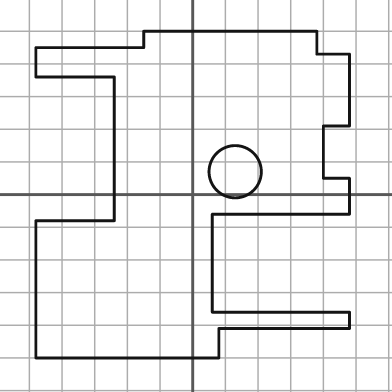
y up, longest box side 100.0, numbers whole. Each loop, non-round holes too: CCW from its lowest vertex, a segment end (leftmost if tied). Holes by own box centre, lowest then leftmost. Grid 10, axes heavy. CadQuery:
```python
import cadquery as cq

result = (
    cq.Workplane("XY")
    .moveTo(-48.0, -50.0)
    .lineTo(8.0, -50.0)
    .lineTo(8.0, -41.0)
    .lineTo(48.0, -41.0)
    .lineTo(48.0, -36.0)
    .lineTo(6.0, -36.0)
    .lineTo(6.0, -6.0)
    .lineTo(48.0, -6.0)
    .lineTo(48.0, 5.0)
    .lineTo(40.0, 5.0)
    .lineTo(40.0, 21.0)
    .lineTo(48.0, 21.0)
    .lineTo(48.0, 43.0)
    .lineTo(38.0, 43.0)
    .lineTo(38.0, 50.0)
    .lineTo(-15.0, 50.0)
    .lineTo(-15.0, 45.0)
    .lineTo(-48.0, 45.0)
    .lineTo(-48.0, 36.0)
    .lineTo(-24.0, 36.0)
    .lineTo(-24.0, -8.0)
    .lineTo(-48.0, -8.0)
    .close()
    .moveTo(13.0, 7.0)
    .circle(8.0)
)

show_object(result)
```